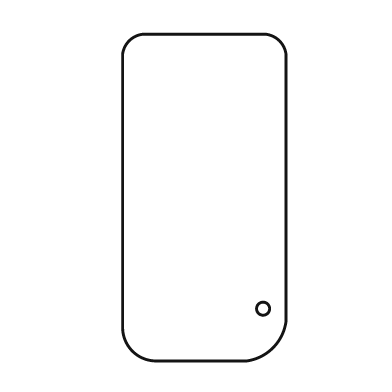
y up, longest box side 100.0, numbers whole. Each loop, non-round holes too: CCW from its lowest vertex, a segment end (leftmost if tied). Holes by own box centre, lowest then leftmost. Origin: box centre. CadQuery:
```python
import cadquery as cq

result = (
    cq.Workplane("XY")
    .moveTo(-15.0, -50.0)
    .lineTo(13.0, -50.0)
    .threePointArc((21.0, -46.0), (25.0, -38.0))
    .lineTo(25.0, 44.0)
    .threePointArc((23.0, 48.0), (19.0, 50.0))
    .lineTo(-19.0, 50.0)
    .threePointArc((-23.0, 48.0), (-25.0, 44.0))
    .lineTo(-25.0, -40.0)
    .threePointArc((-22.0, -47.0), (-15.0, -50.0))
    .close()
    .moveTo(18.0, -34.0)
    .circle(2.0)
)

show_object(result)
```